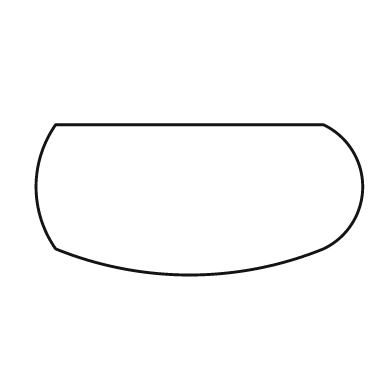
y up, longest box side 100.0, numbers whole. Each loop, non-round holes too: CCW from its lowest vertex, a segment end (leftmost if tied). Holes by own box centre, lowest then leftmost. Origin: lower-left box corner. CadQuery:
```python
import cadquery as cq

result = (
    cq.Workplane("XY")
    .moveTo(6.0, 8.0)
    .threePointArc((47.0, 0.0), (88.0, 8.0))
    .threePointArc((100.0, 27.0), (88.0, 46.0))
    .lineTo(6.0, 46.0)
    .threePointArc((0.0, 27.0), (6.0, 8.0))
    .close()
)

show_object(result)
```